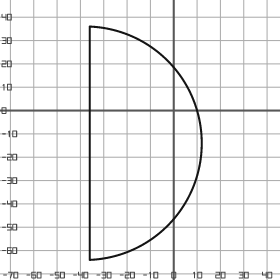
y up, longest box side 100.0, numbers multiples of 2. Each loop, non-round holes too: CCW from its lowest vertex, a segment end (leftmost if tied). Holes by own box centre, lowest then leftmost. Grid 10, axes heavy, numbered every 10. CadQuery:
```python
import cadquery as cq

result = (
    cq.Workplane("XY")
    .moveTo(-36.0, -64.0)
    .threePointArc((12.0, -14.0), (-36.0, 36.0))
    .close()
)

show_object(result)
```